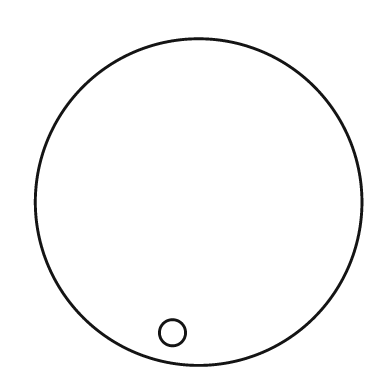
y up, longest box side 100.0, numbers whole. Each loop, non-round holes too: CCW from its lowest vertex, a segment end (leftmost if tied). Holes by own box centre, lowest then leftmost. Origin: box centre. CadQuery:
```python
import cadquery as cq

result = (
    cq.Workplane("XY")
    .moveTo(0.0, 0.0)
    .circle(50.0)
    .moveTo(-8.0, -40.0)
    .circle(4.0)
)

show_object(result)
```